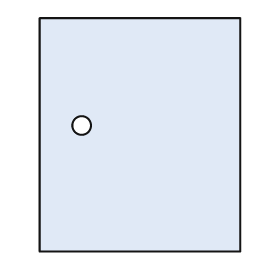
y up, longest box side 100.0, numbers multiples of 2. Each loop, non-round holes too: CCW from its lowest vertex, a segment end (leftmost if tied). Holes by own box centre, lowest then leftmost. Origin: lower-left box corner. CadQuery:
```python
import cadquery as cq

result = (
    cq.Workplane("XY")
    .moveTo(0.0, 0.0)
    .lineTo(86.0, 0.0)
    .lineTo(86.0, 100.0)
    .lineTo(0.0, 100.0)
    .close()
    .moveTo(18.0, 54.0)
    .circle(4.0)
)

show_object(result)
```